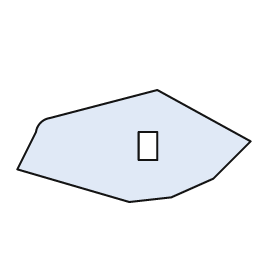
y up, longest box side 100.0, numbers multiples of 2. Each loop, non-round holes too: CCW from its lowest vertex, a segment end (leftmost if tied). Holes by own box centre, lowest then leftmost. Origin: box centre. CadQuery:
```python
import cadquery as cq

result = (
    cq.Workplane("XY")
    .moveTo(-2.0, -24.0)
    .lineTo(16.0, -22.0)
    .lineTo(34.0, -14.0)
    .lineTo(50.0, 2.0)
    .lineTo(10.0, 24.0)
    .lineTo(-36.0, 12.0)
    .threePointArc((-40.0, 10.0), (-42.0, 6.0))
    .lineTo(-50.0, -10.0)
    .close()
    .moveTo(2.0, -6.0)
    .lineTo(10.0, -6.0)
    .lineTo(10.0, 6.0)
    .lineTo(2.0, 6.0)
    .close()
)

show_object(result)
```